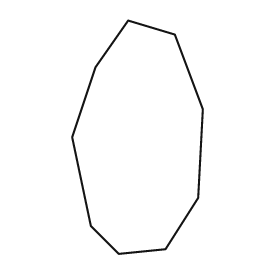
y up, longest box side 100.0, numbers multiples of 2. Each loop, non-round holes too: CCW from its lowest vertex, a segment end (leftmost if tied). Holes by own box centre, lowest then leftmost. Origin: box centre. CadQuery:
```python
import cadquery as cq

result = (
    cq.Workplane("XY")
    .moveTo(-8.0, -50.0)
    .lineTo(12.0, -48.0)
    .lineTo(26.0, -26.0)
    .lineTo(28.0, 12.0)
    .lineTo(16.0, 44.0)
    .lineTo(-4.0, 50.0)
    .lineTo(-18.0, 30.0)
    .lineTo(-28.0, 0.0)
    .lineTo(-20.0, -38.0)
    .close()
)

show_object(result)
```